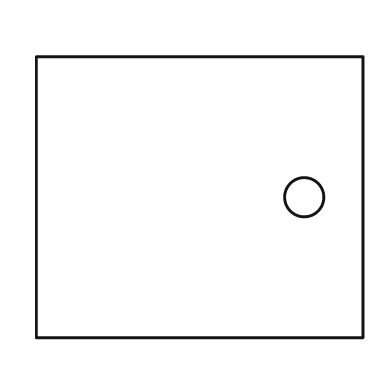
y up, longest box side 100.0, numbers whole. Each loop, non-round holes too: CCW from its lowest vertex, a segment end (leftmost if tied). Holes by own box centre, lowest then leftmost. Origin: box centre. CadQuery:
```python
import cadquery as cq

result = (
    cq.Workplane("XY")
    .moveTo(-50.0, -43.0)
    .lineTo(50.0, -43.0)
    .lineTo(50.0, 43.0)
    .lineTo(-50.0, 43.0)
    .close()
    .moveTo(32.0, 0.0)
    .circle(6.0)
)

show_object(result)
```